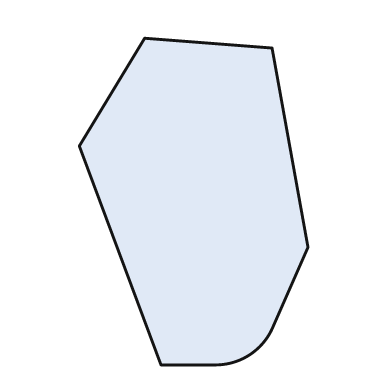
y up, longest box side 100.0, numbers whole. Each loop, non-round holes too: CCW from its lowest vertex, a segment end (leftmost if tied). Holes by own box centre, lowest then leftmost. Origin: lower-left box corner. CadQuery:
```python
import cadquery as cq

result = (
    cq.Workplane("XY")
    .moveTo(25.0, 0.0)
    .lineTo(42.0, 0.0)
    .threePointArc((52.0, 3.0), (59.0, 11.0))
    .lineTo(70.0, 36.0)
    .lineTo(59.0, 97.0)
    .lineTo(20.0, 100.0)
    .lineTo(0.0, 67.0)
    .close()
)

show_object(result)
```